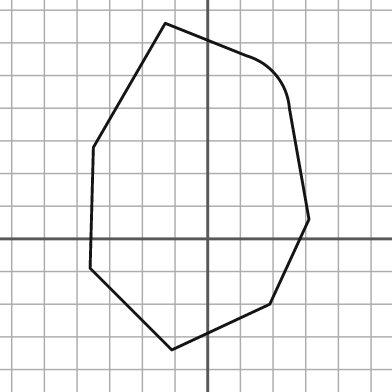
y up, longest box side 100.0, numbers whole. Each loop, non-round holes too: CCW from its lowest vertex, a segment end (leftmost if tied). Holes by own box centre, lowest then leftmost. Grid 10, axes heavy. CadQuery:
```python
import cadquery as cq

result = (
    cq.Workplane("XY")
    .moveTo(-11.0, -34.0)
    .lineTo(19.0, -20.0)
    .lineTo(31.0, 6.0)
    .lineTo(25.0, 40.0)
    .threePointArc((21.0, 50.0), (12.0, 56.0))
    .lineTo(-13.0, 66.0)
    .lineTo(-35.0, 28.0)
    .lineTo(-36.0, -9.0)
    .close()
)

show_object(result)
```